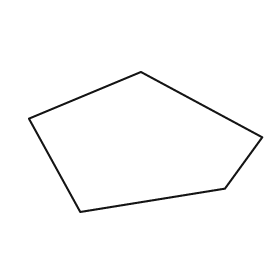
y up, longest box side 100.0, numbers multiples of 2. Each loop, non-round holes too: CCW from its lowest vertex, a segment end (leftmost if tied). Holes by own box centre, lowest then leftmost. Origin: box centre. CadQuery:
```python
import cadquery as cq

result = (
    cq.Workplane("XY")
    .moveTo(-28.0, -30.0)
    .lineTo(34.0, -20.0)
    .lineTo(50.0, 2.0)
    .lineTo(-2.0, 30.0)
    .lineTo(-50.0, 10.0)
    .close()
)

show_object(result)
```